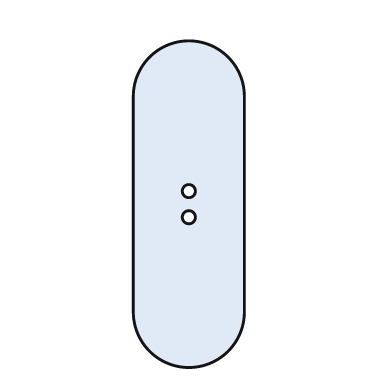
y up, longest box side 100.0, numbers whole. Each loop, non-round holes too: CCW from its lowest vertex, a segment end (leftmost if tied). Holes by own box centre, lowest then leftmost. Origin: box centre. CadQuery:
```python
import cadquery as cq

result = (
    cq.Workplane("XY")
    .moveTo(-17.0, -33.0)
    .threePointArc((0.0, -50.0), (17.0, -33.0))
    .lineTo(17.0, 33.0)
    .threePointArc((0.0, 50.0), (-17.0, 33.0))
    .close()
    .moveTo(0.0, -4.0)
    .circle(2.0)
    .moveTo(0.0, 4.0)
    .circle(2.0)
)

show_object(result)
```